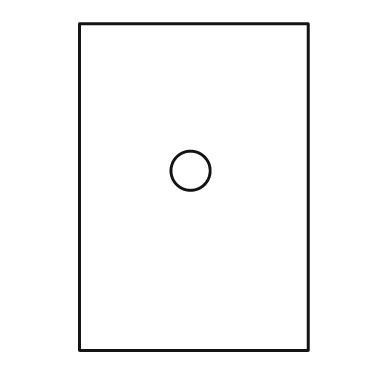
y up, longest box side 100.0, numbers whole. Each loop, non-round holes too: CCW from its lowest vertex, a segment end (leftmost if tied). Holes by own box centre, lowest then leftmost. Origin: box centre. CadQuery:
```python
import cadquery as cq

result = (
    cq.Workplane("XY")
    .moveTo(-35.0, -50.0)
    .lineTo(35.0, -50.0)
    .lineTo(35.0, 50.0)
    .lineTo(-35.0, 50.0)
    .close()
    .moveTo(-1.0, 5.0)
    .circle(6.0)
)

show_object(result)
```